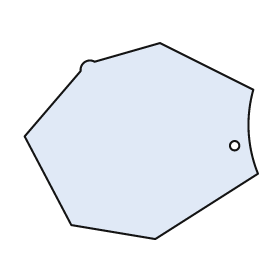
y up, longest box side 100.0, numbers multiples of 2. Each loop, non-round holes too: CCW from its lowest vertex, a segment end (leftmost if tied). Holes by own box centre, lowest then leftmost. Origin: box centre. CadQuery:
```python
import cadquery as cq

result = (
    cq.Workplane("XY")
    .moveTo(6.0, -42.0)
    .lineTo(50.0, -14.0)
    .threePointArc((46.0, 4.0), (48.0, 22.0))
    .lineTo(8.0, 42.0)
    .lineTo(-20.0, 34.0)
    .threePointArc((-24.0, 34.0), (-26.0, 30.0))
    .lineTo(-50.0, 2.0)
    .lineTo(-30.0, -36.0)
    .close()
    .moveTo(40.0, -2.0)
    .circle(2.0)
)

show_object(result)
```